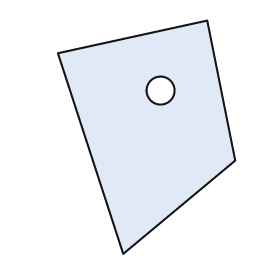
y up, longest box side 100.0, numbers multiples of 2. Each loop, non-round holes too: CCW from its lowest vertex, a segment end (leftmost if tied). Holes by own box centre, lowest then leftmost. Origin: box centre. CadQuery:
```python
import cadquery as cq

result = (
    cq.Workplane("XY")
    .moveTo(-10.0, -50.0)
    .lineTo(38.0, -10.0)
    .lineTo(26.0, 50.0)
    .lineTo(-38.0, 36.0)
    .close()
    .moveTo(6.0, 20.0)
    .circle(6.0)
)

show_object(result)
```